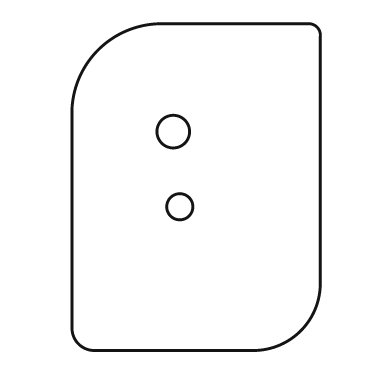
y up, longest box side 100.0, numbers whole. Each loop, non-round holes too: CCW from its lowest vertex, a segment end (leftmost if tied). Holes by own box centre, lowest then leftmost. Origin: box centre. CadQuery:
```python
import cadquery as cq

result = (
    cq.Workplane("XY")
    .moveTo(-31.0, -50.0)
    .lineTo(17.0, -50.0)
    .threePointArc((32.0, -44.0), (38.0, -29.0))
    .lineTo(38.0, 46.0)
    .threePointArc((37.0, 49.0), (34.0, 50.0))
    .lineTo(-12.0, 50.0)
    .threePointArc((-30.0, 42.0), (-38.0, 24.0))
    .lineTo(-38.0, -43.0)
    .threePointArc((-36.0, -48.0), (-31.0, -50.0))
    .close()
    .moveTo(-5.0, -6.0)
    .circle(4.0)
    .moveTo(-7.0, 17.0)
    .circle(5.0)
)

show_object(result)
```